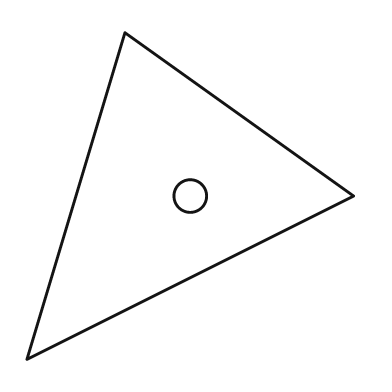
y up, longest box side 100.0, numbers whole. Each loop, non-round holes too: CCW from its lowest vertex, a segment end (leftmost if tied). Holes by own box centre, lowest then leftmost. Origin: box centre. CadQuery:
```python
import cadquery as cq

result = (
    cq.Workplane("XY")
    .moveTo(-50.0, -50.0)
    .lineTo(50.0, 0.0)
    .lineTo(-20.0, 50.0)
    .close()
    .moveTo(0.0, 0.0)
    .circle(5.0)
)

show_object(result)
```